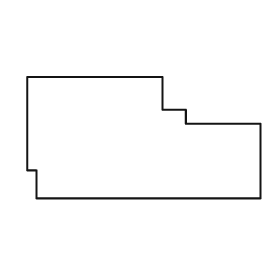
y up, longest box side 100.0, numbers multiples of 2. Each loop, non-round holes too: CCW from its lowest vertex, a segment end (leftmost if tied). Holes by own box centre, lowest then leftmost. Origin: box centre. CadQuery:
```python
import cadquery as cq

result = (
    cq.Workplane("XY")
    .moveTo(-46.0, -26.0)
    .lineTo(50.0, -26.0)
    .lineTo(50.0, 6.0)
    .lineTo(18.0, 6.0)
    .lineTo(18.0, 12.0)
    .lineTo(8.0, 12.0)
    .lineTo(8.0, 26.0)
    .lineTo(-50.0, 26.0)
    .lineTo(-50.0, -14.0)
    .lineTo(-46.0, -14.0)
    .close()
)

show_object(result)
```